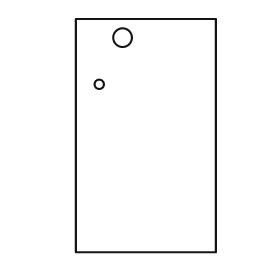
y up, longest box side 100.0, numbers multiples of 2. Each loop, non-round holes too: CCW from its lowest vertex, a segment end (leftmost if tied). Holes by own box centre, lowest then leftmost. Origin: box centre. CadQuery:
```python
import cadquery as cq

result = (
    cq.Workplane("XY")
    .moveTo(-30.0, -50.0)
    .lineTo(30.0, -50.0)
    .lineTo(30.0, 50.0)
    .lineTo(-30.0, 50.0)
    .close()
    .moveTo(-20.0, 22.0)
    .circle(2.0)
    .moveTo(-10.0, 42.0)
    .circle(4.0)
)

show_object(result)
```